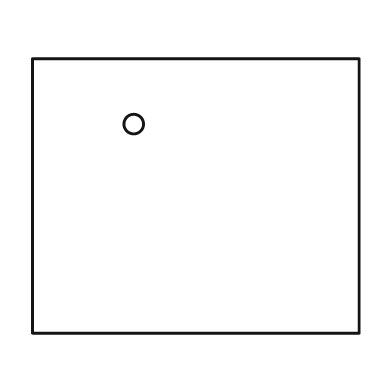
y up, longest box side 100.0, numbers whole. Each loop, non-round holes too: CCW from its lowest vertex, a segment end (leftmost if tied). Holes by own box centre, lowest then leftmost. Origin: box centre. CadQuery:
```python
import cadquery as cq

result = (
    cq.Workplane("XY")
    .moveTo(-50.0, -42.0)
    .lineTo(50.0, -42.0)
    .lineTo(50.0, 42.0)
    .lineTo(-50.0, 42.0)
    .close()
    .moveTo(-19.0, 22.0)
    .circle(3.0)
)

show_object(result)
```